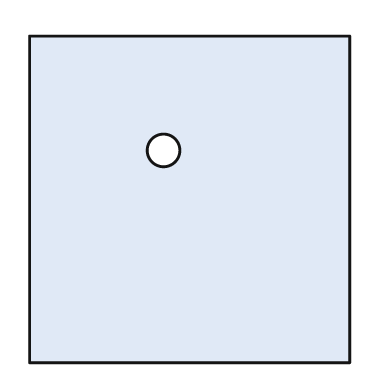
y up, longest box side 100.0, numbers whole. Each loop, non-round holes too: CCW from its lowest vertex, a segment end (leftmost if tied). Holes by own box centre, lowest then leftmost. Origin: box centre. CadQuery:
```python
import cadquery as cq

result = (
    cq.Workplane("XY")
    .moveTo(-49.0, -50.0)
    .lineTo(49.0, -50.0)
    .lineTo(49.0, 50.0)
    .lineTo(-49.0, 50.0)
    .close()
    .moveTo(-8.0, 15.0)
    .circle(5.0)
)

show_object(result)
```